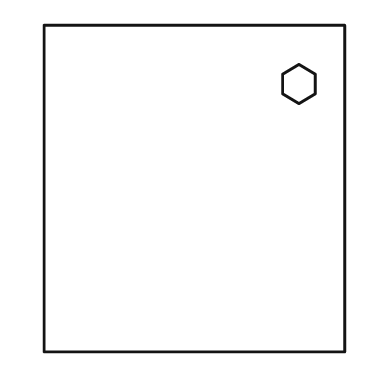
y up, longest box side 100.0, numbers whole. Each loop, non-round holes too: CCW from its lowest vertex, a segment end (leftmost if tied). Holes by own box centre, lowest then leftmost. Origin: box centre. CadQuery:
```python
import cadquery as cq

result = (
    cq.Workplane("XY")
    .moveTo(-46.0, -50.0)
    .lineTo(46.0, -50.0)
    .lineTo(46.0, 50.0)
    .lineTo(-46.0, 50.0)
    .close()
    .moveTo(32.0, 26.0)
    .lineTo(37.0, 29.0)
    .lineTo(37.0, 35.0)
    .lineTo(32.0, 38.0)
    .lineTo(27.0, 35.0)
    .lineTo(27.0, 29.0)
    .close()
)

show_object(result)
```